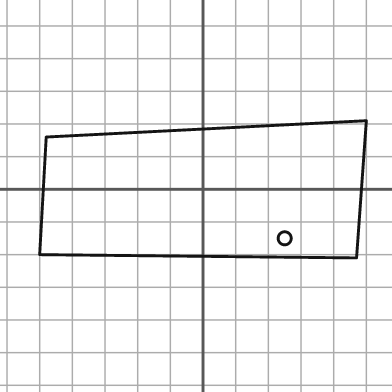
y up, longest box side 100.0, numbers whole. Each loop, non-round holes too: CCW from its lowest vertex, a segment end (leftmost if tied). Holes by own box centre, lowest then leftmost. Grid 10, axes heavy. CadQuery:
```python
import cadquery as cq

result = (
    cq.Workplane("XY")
    .moveTo(47.0, -21.0)
    .lineTo(50.0, 21.0)
    .lineTo(-48.0, 16.0)
    .lineTo(-50.0, -20.0)
    .close()
    .moveTo(25.0, -15.0)
    .circle(2.0)
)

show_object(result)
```